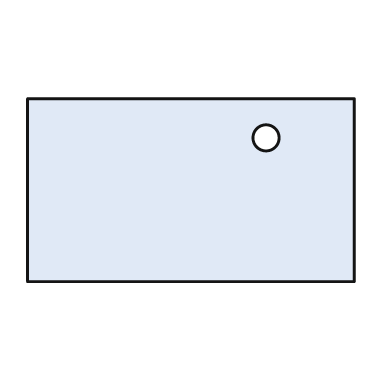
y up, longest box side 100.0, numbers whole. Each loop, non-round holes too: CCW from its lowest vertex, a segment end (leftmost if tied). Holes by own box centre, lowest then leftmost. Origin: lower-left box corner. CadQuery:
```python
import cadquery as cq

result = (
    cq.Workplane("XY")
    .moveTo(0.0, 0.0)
    .lineTo(100.0, 0.0)
    .lineTo(100.0, 56.0)
    .lineTo(0.0, 56.0)
    .close()
    .moveTo(73.0, 44.0)
    .circle(4.0)
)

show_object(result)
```